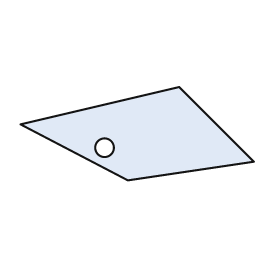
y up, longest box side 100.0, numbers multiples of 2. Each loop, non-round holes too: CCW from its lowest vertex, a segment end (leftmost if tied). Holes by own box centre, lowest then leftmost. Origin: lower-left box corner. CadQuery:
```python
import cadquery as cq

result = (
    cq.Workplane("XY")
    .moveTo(46.0, 0.0)
    .lineTo(100.0, 8.0)
    .lineTo(68.0, 40.0)
    .lineTo(0.0, 24.0)
    .close()
    .moveTo(36.0, 14.0)
    .circle(4.0)
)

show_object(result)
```